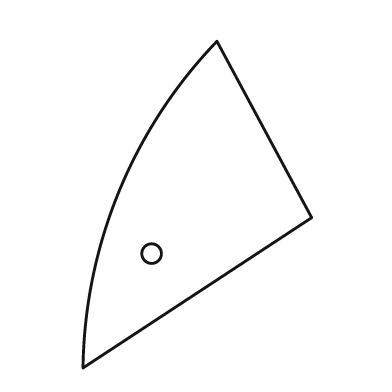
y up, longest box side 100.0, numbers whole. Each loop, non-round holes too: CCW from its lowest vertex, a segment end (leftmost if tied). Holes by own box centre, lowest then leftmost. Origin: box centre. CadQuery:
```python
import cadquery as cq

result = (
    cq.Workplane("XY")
    .moveTo(-35.0, -50.0)
    .lineTo(35.0, -4.0)
    .lineTo(6.0, 50.0)
    .threePointArc((-24.0, 4.0), (-35.0, -50.0))
    .close()
    .moveTo(-14.0, -15.0)
    .circle(3.0)
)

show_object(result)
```